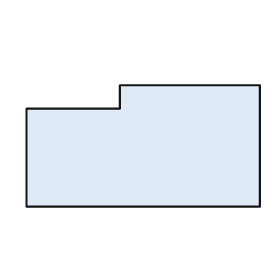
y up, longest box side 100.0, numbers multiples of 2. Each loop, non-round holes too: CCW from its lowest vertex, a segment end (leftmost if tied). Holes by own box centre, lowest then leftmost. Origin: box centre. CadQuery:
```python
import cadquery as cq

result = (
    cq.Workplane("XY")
    .moveTo(-50.0, -26.0)
    .lineTo(50.0, -26.0)
    .lineTo(50.0, 26.0)
    .lineTo(-10.0, 26.0)
    .lineTo(-10.0, 16.0)
    .lineTo(-50.0, 16.0)
    .close()
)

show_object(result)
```